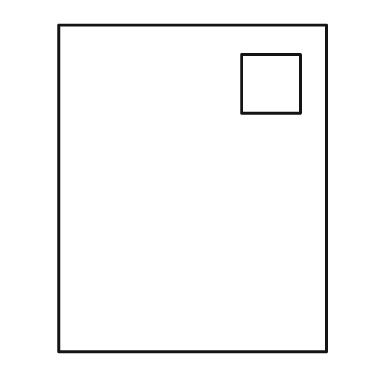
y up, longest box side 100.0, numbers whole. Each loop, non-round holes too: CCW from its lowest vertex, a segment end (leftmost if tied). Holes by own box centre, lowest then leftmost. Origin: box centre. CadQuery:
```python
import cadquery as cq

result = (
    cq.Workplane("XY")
    .moveTo(-41.0, -50.0)
    .lineTo(41.0, -50.0)
    .lineTo(41.0, 50.0)
    .lineTo(-41.0, 50.0)
    .close()
    .moveTo(15.0, 23.0)
    .lineTo(33.0, 23.0)
    .lineTo(33.0, 41.0)
    .lineTo(15.0, 41.0)
    .close()
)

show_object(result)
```